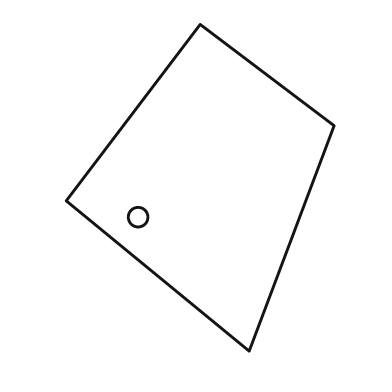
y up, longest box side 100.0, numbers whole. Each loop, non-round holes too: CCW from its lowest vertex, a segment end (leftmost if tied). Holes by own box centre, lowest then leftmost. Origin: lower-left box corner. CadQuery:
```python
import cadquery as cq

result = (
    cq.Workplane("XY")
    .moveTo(56.0, 0.0)
    .lineTo(82.0, 69.0)
    .lineTo(41.0, 100.0)
    .lineTo(0.0, 46.0)
    .close()
    .moveTo(22.0, 41.0)
    .circle(3.0)
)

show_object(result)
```